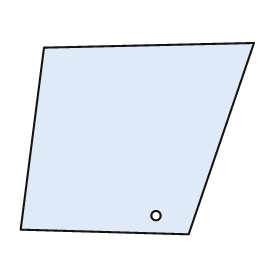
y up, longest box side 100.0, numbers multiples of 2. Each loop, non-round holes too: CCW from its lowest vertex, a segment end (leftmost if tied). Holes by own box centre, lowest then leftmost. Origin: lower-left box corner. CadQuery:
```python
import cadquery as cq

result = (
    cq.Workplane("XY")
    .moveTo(72.0, 0.0)
    .lineTo(100.0, 82.0)
    .lineTo(10.0, 80.0)
    .lineTo(0.0, 2.0)
    .close()
    .moveTo(58.0, 8.0)
    .circle(2.0)
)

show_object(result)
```